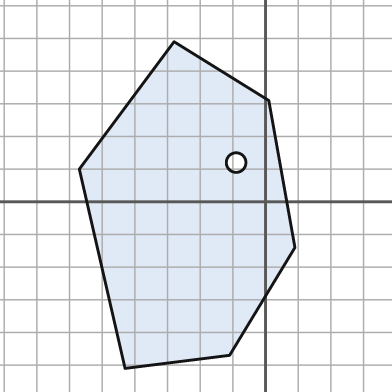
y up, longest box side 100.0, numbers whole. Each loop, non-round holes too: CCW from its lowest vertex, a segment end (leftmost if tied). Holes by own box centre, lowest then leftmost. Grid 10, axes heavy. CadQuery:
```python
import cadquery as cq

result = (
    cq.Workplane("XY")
    .moveTo(-43.0, -51.0)
    .lineTo(-11.0, -47.0)
    .lineTo(9.0, -14.0)
    .lineTo(1.0, 31.0)
    .lineTo(-28.0, 49.0)
    .lineTo(-57.0, 10.0)
    .close()
    .moveTo(-9.0, 12.0)
    .circle(3.0)
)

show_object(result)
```